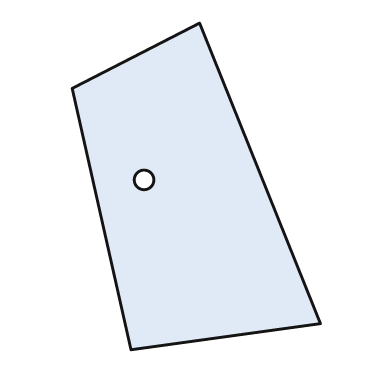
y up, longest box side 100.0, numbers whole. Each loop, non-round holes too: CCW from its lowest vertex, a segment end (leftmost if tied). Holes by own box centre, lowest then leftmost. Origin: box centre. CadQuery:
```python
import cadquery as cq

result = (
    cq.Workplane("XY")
    .moveTo(-20.0, -50.0)
    .lineTo(38.0, -42.0)
    .lineTo(1.0, 50.0)
    .lineTo(-38.0, 30.0)
    .close()
    .moveTo(-16.0, 2.0)
    .circle(3.0)
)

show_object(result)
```